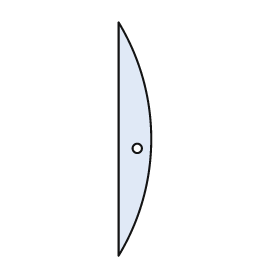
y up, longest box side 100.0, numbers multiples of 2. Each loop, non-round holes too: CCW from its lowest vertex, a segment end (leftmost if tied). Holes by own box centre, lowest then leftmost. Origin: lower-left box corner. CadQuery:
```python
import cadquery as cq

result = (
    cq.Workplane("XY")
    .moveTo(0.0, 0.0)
    .threePointArc((14.0, 50.0), (0.0, 100.0))
    .close()
    .moveTo(8.0, 46.0)
    .circle(2.0)
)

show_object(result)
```